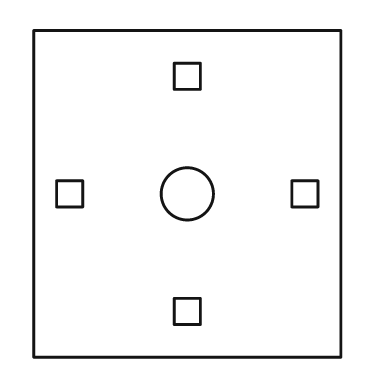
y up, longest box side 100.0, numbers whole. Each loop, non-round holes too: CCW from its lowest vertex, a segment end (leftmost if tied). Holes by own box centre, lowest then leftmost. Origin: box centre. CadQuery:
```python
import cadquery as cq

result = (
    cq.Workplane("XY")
    .moveTo(-47.0, -50.0)
    .lineTo(47.0, -50.0)
    .lineTo(47.0, 50.0)
    .lineTo(-47.0, 50.0)
    .close()
    .moveTo(-4.0, -40.0)
    .lineTo(4.0, -40.0)
    .lineTo(4.0, -32.0)
    .lineTo(-4.0, -32.0)
    .close()
    .moveTo(-40.0, -4.0)
    .lineTo(-32.0, -4.0)
    .lineTo(-32.0, 4.0)
    .lineTo(-40.0, 4.0)
    .close()
    .moveTo(0.0, 0.0)
    .circle(8.0)
    .moveTo(32.0, -4.0)
    .lineTo(40.0, -4.0)
    .lineTo(40.0, 4.0)
    .lineTo(32.0, 4.0)
    .close()
    .moveTo(-4.0, 32.0)
    .lineTo(4.0, 32.0)
    .lineTo(4.0, 40.0)
    .lineTo(-4.0, 40.0)
    .close()
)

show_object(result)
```